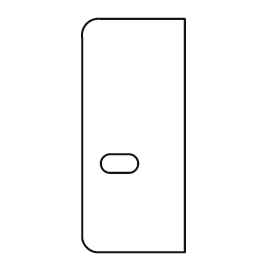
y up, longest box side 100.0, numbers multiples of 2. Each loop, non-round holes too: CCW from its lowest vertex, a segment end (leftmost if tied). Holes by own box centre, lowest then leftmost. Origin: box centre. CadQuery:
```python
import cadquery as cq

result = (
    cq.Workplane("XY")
    .moveTo(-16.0, -50.0)
    .lineTo(22.0, -50.0)
    .lineTo(22.0, 50.0)
    .lineTo(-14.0, 50.0)
    .threePointArc((-20.0, 48.0), (-22.0, 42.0))
    .lineTo(-22.0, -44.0)
    .threePointArc((-20.0, -48.0), (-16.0, -50.0))
    .close()
    .moveTo(-10.0, -16.0)
    .lineTo(-2.0, -16.0)
    .threePointArc((2.0, -12.0), (-2.0, -8.0))
    .lineTo(-10.0, -8.0)
    .threePointArc((-14.0, -12.0), (-10.0, -16.0))
    .close()
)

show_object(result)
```